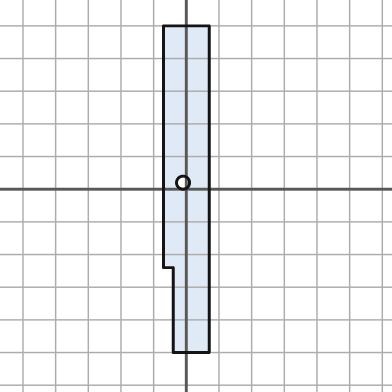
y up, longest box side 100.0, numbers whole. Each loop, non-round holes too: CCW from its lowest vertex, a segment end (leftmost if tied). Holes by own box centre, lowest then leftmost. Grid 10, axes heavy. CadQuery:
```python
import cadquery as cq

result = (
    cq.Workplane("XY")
    .moveTo(-4.0, -50.0)
    .lineTo(7.0, -50.0)
    .lineTo(7.0, 50.0)
    .lineTo(-7.0, 50.0)
    .lineTo(-7.0, -24.0)
    .lineTo(-4.0, -24.0)
    .close()
    .moveTo(-1.0, 2.0)
    .circle(2.0)
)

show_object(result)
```